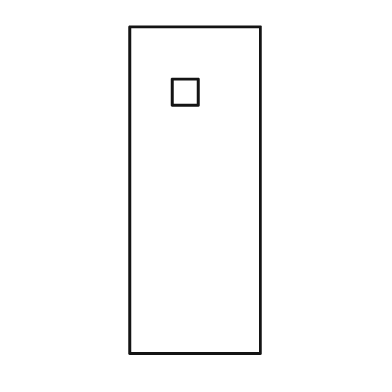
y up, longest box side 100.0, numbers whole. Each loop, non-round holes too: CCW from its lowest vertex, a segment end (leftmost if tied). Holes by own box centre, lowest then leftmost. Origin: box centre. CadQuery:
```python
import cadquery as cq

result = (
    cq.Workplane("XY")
    .moveTo(-20.0, -50.0)
    .lineTo(20.0, -50.0)
    .lineTo(20.0, 50.0)
    .lineTo(-20.0, 50.0)
    .close()
    .moveTo(-7.0, 26.0)
    .lineTo(1.0, 26.0)
    .lineTo(1.0, 34.0)
    .lineTo(-7.0, 34.0)
    .close()
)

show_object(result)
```